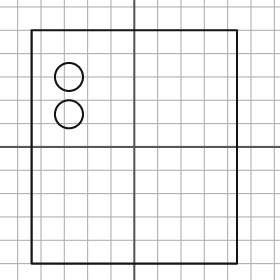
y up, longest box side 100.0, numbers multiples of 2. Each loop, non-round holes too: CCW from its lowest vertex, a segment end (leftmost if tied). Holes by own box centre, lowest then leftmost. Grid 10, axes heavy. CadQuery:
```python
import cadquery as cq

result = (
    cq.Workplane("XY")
    .moveTo(-44.0, -50.0)
    .lineTo(44.0, -50.0)
    .lineTo(44.0, 50.0)
    .lineTo(-44.0, 50.0)
    .close()
    .moveTo(-28.0, 14.0)
    .circle(6.0)
    .moveTo(-28.0, 30.0)
    .circle(6.0)
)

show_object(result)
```